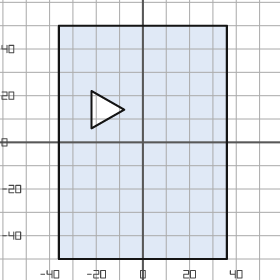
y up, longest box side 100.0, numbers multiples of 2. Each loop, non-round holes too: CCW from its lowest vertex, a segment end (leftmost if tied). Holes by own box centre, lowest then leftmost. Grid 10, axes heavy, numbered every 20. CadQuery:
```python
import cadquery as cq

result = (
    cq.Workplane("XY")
    .moveTo(-36.0, -50.0)
    .lineTo(36.0, -50.0)
    .lineTo(36.0, 50.0)
    .lineTo(-36.0, 50.0)
    .close()
    .moveTo(-22.0, 6.0)
    .lineTo(-8.0, 14.0)
    .lineTo(-22.0, 22.0)
    .close()
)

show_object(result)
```